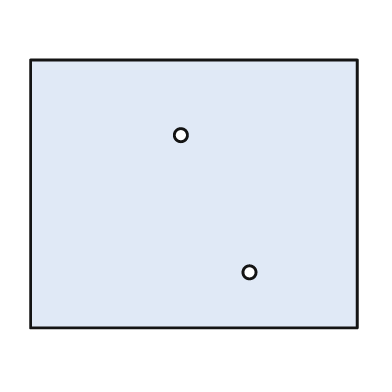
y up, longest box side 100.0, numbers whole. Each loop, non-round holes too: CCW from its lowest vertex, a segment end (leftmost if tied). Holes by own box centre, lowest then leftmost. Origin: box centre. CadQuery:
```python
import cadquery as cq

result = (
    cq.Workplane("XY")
    .moveTo(-50.0, -41.0)
    .lineTo(50.0, -41.0)
    .lineTo(50.0, 41.0)
    .lineTo(-50.0, 41.0)
    .close()
    .moveTo(17.0, -24.0)
    .circle(2.0)
    .moveTo(-4.0, 18.0)
    .circle(2.0)
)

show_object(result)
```